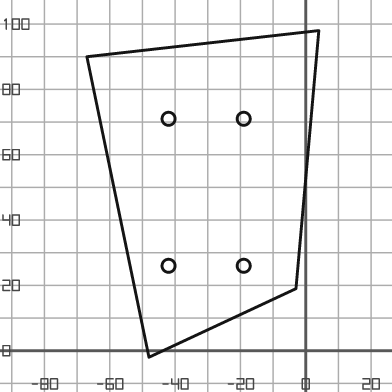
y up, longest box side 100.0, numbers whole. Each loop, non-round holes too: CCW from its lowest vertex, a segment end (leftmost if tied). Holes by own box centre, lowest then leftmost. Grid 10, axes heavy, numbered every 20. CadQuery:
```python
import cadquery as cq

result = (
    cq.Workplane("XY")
    .moveTo(-48.0, -2.0)
    .lineTo(-3.0, 19.0)
    .lineTo(4.0, 98.0)
    .lineTo(-67.0, 90.0)
    .close()
    .moveTo(-42.0, 26.0)
    .circle(2.0)
    .moveTo(-19.0, 26.0)
    .circle(2.0)
    .moveTo(-42.0, 71.0)
    .circle(2.0)
    .moveTo(-19.0, 71.0)
    .circle(2.0)
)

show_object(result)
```